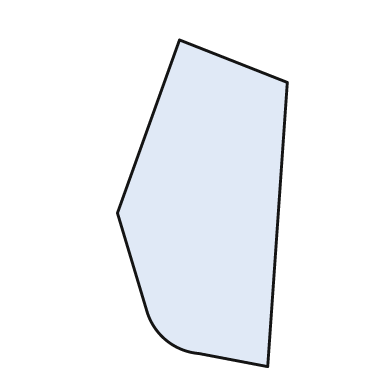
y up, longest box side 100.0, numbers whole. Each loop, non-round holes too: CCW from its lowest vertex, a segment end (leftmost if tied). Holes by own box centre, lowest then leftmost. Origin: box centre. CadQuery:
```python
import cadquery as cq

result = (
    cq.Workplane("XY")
    .moveTo(20.0, -50.0)
    .lineTo(26.0, 37.0)
    .lineTo(-7.0, 50.0)
    .lineTo(-26.0, -3.0)
    .lineTo(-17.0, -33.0)
    .threePointArc((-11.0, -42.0), (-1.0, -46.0))
    .close()
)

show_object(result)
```